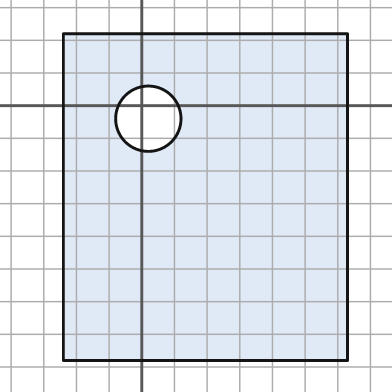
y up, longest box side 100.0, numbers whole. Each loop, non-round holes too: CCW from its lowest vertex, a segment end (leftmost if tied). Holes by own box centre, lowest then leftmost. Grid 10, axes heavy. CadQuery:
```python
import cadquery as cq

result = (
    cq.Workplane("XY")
    .moveTo(-24.0, -78.0)
    .lineTo(63.0, -78.0)
    .lineTo(63.0, 22.0)
    .lineTo(-24.0, 22.0)
    .close()
    .moveTo(2.0, -4.0)
    .circle(10.0)
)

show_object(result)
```